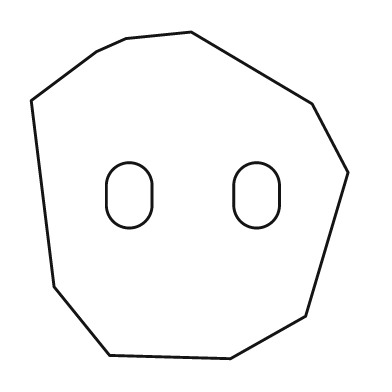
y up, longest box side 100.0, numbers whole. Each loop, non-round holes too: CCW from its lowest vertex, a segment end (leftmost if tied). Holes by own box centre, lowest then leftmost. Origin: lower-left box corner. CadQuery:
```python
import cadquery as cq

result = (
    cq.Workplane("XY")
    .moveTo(61.0, 0.0)
    .lineTo(84.0, 13.0)
    .lineTo(97.0, 57.0)
    .lineTo(86.0, 78.0)
    .lineTo(49.0, 100.0)
    .lineTo(29.0, 98.0)
    .lineTo(20.0, 94.0)
    .lineTo(0.0, 79.0)
    .lineTo(7.0, 22.0)
    .lineTo(24.0, 1.0)
    .close()
    .moveTo(23.0, 47.0)
    .threePointArc((30.0, 40.0), (37.0, 47.0))
    .lineTo(37.0, 53.0)
    .threePointArc((30.0, 60.0), (23.0, 53.0))
    .close()
    .moveTo(62.0, 47.0)
    .threePointArc((69.0, 40.0), (76.0, 47.0))
    .lineTo(76.0, 53.0)
    .threePointArc((69.0, 60.0), (62.0, 53.0))
    .close()
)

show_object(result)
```